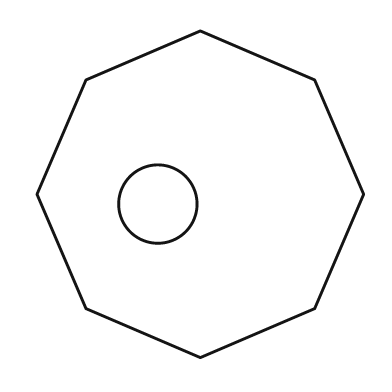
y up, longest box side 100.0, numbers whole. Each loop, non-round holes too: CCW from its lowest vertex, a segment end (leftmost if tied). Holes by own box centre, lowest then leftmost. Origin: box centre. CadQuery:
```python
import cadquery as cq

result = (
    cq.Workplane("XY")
    .moveTo(0.0, -50.0)
    .lineTo(35.0, -35.0)
    .lineTo(50.0, 0.0)
    .lineTo(35.0, 35.0)
    .lineTo(0.0, 50.0)
    .lineTo(-35.0, 35.0)
    .lineTo(-50.0, 0.0)
    .lineTo(-35.0, -35.0)
    .close()
    .moveTo(-13.0, -3.0)
    .circle(12.0)
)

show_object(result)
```